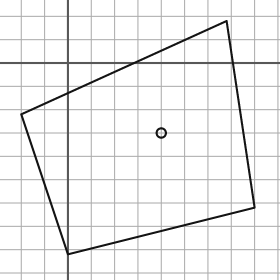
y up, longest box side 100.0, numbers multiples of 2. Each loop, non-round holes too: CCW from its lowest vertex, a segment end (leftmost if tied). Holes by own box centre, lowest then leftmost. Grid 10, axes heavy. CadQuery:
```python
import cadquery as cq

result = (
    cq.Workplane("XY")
    .moveTo(0.0, -82.0)
    .lineTo(80.0, -62.0)
    .lineTo(68.0, 18.0)
    .lineTo(-20.0, -22.0)
    .close()
    .moveTo(40.0, -30.0)
    .circle(2.0)
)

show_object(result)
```